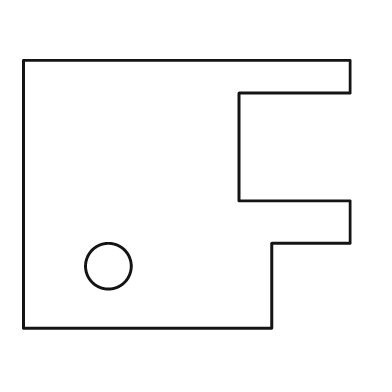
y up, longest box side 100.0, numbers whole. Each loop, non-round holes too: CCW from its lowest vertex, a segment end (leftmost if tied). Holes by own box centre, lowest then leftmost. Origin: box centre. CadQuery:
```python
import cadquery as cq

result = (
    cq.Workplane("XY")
    .moveTo(-50.0, -41.0)
    .lineTo(26.0, -41.0)
    .lineTo(26.0, -15.0)
    .lineTo(50.0, -15.0)
    .lineTo(50.0, -2.0)
    .lineTo(16.0, -2.0)
    .lineTo(16.0, 31.0)
    .lineTo(50.0, 31.0)
    .lineTo(50.0, 41.0)
    .lineTo(-50.0, 41.0)
    .close()
    .moveTo(-24.0, -22.0)
    .circle(7.0)
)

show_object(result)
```